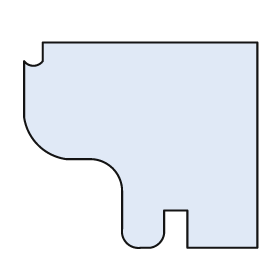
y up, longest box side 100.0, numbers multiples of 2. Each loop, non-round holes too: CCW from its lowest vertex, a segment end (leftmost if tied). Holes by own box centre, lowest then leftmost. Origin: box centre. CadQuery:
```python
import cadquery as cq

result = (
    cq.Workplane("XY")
    .moveTo(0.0, -44.0)
    .lineTo(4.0, -44.0)
    .threePointArc((8.0, -42.0), (10.0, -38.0))
    .lineTo(10.0, -28.0)
    .lineTo(20.0, -28.0)
    .lineTo(20.0, -44.0)
    .lineTo(50.0, -44.0)
    .lineTo(50.0, 44.0)
    .lineTo(-42.0, 44.0)
    .lineTo(-42.0, 36.0)
    .threePointArc((-46.0, 34.0), (-50.0, 36.0))
    .lineTo(-50.0, 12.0)
    .threePointArc((-44.0, 0.0), (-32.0, -6.0))
    .lineTo(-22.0, -6.0)
    .threePointArc((-12.0, -10.0), (-8.0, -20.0))
    .lineTo(-8.0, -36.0)
    .threePointArc((-6.0, -42.0), (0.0, -44.0))
    .close()
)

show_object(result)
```